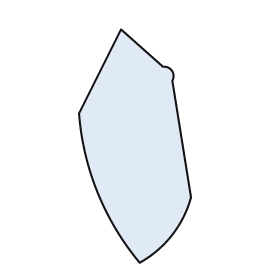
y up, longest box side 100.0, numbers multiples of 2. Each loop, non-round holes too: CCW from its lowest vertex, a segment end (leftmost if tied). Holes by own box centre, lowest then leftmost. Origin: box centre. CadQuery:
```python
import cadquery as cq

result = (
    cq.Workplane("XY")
    .moveTo(2.0, -50.0)
    .threePointArc((16.0, -38.0), (24.0, -22.0))
    .lineTo(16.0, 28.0)
    .threePointArc((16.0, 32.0), (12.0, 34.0))
    .lineTo(-6.0, 50.0)
    .lineTo(-24.0, 14.0)
    .threePointArc((-16.0, -20.0), (2.0, -50.0))
    .close()
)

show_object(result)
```